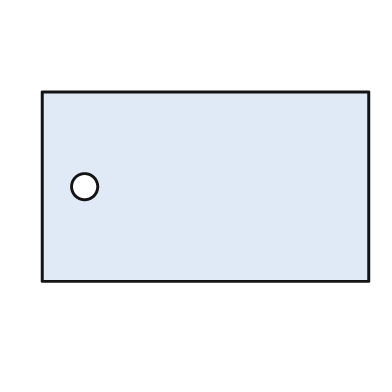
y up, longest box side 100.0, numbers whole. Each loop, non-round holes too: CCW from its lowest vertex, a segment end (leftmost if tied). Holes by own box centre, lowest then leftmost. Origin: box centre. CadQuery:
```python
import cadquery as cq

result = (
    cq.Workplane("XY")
    .moveTo(-50.0, -29.0)
    .lineTo(50.0, -29.0)
    .lineTo(50.0, 29.0)
    .lineTo(-50.0, 29.0)
    .close()
    .moveTo(-37.0, 0.0)
    .circle(4.0)
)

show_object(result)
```